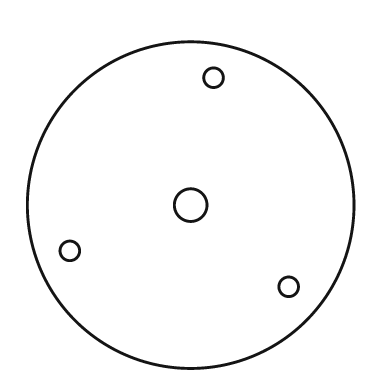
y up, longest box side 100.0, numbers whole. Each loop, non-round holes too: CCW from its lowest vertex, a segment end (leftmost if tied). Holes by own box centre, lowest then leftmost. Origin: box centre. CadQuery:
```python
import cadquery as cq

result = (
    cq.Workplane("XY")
    .moveTo(0.0, 0.0)
    .circle(50.0)
    .moveTo(30.0, -25.0)
    .circle(3.0)
    .moveTo(-37.0, -14.0)
    .circle(3.0)
    .moveTo(0.0, 0.0)
    .circle(5.0)
    .moveTo(7.0, 39.0)
    .circle(3.0)
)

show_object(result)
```